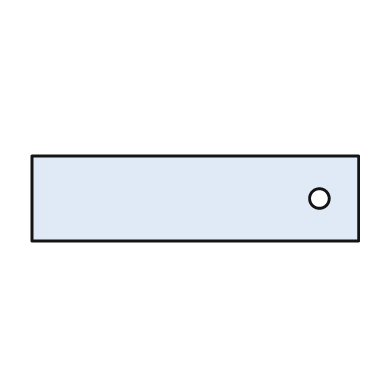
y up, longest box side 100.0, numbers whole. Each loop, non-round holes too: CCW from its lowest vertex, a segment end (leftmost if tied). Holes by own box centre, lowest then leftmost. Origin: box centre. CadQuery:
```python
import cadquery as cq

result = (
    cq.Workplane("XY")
    .moveTo(-50.0, -13.0)
    .lineTo(50.0, -13.0)
    .lineTo(50.0, 13.0)
    .lineTo(-50.0, 13.0)
    .close()
    .moveTo(38.0, 0.0)
    .circle(3.0)
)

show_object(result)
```